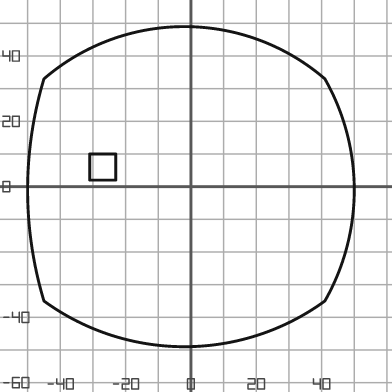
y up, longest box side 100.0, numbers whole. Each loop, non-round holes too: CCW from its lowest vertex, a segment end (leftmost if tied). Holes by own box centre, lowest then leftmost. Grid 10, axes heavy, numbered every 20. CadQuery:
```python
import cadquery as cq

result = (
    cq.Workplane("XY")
    .moveTo(-45.0, -35.0)
    .threePointArc((-2.0, -49.0), (41.0, -35.0))
    .threePointArc((50.0, -1.0), (41.0, 33.0))
    .threePointArc((-2.0, 49.0), (-45.0, 33.0))
    .threePointArc((-50.0, -1.0), (-45.0, -35.0))
    .close()
    .moveTo(-31.0, 2.0)
    .lineTo(-23.0, 2.0)
    .lineTo(-23.0, 10.0)
    .lineTo(-31.0, 10.0)
    .close()
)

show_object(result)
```